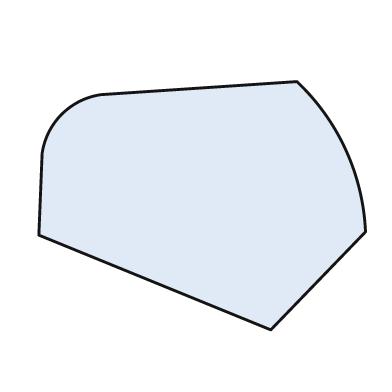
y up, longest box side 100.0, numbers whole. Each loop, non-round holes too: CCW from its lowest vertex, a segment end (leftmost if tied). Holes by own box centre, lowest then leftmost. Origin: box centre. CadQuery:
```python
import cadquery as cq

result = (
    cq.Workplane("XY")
    .moveTo(21.0, -38.0)
    .lineTo(50.0, -8.0)
    .threePointArc((44.0, 17.0), (29.0, 38.0))
    .lineTo(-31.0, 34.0)
    .threePointArc((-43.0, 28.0), (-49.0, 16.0))
    .lineTo(-50.0, -9.0)
    .close()
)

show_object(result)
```